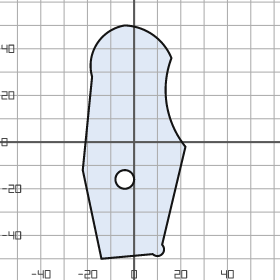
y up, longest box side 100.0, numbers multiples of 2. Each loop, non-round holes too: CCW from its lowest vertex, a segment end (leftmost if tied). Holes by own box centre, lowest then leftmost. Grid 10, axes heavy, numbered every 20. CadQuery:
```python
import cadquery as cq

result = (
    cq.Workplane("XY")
    .moveTo(-14.0, -50.0)
    .lineTo(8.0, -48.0)
    .threePointArc((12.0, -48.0), (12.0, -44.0))
    .lineTo(22.0, -2.0)
    .threePointArc((14.0, 16.0), (16.0, 36.0))
    .threePointArc((8.0, 46.0), (-4.0, 50.0))
    .threePointArc((-16.0, 42.0), (-18.0, 28.0))
    .lineTo(-22.0, -12.0)
    .close()
    .moveTo(-4.0, -16.0)
    .circle(4.0)
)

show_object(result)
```